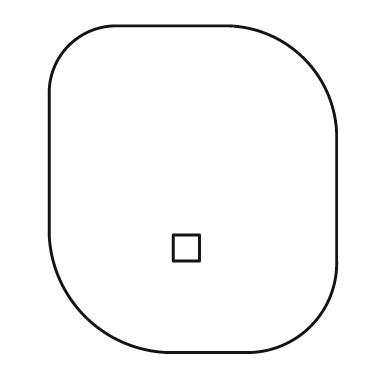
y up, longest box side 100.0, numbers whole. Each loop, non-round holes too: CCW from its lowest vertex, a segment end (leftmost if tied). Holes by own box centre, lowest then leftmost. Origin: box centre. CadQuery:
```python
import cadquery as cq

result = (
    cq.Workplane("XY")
    .moveTo(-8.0, -50.0)
    .lineTo(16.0, -50.0)
    .threePointArc((36.0, -42.0), (44.0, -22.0))
    .lineTo(44.0, 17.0)
    .threePointArc((34.0, 40.0), (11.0, 50.0))
    .lineTo(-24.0, 50.0)
    .threePointArc((-38.0, 44.0), (-44.0, 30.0))
    .lineTo(-44.0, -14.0)
    .threePointArc((-33.0, -39.0), (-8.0, -50.0))
    .close()
    .moveTo(-6.0, -22.0)
    .lineTo(2.0, -22.0)
    .lineTo(2.0, -14.0)
    .lineTo(-6.0, -14.0)
    .close()
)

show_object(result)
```